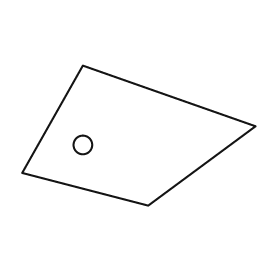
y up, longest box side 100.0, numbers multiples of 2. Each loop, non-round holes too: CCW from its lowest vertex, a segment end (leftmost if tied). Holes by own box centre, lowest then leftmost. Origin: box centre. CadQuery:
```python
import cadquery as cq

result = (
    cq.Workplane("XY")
    .moveTo(4.0, -30.0)
    .lineTo(50.0, 4.0)
    .lineTo(-24.0, 30.0)
    .lineTo(-50.0, -16.0)
    .close()
    .moveTo(-24.0, -4.0)
    .circle(4.0)
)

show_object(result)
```